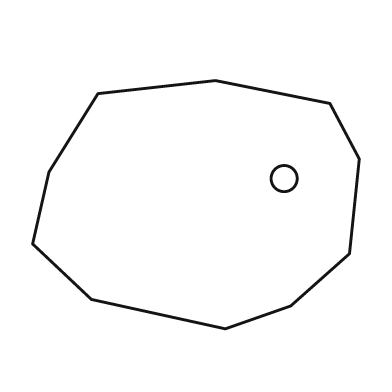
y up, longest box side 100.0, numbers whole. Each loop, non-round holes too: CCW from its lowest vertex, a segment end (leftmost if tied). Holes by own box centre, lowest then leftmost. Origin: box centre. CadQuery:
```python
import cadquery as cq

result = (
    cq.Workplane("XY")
    .moveTo(9.0, -38.0)
    .lineTo(29.0, -31.0)
    .lineTo(47.0, -15.0)
    .lineTo(50.0, 14.0)
    .lineTo(41.0, 31.0)
    .lineTo(6.0, 38.0)
    .lineTo(-30.0, 34.0)
    .lineTo(-45.0, 10.0)
    .lineTo(-50.0, -12.0)
    .lineTo(-32.0, -29.0)
    .close()
    .moveTo(27.0, 8.0)
    .circle(4.0)
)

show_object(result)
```